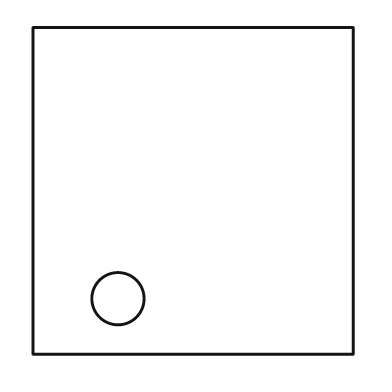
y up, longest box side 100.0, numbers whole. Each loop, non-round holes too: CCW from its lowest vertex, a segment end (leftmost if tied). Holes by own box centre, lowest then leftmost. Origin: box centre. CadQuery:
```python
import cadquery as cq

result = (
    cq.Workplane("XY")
    .moveTo(-49.0, -50.0)
    .lineTo(49.0, -50.0)
    .lineTo(49.0, 50.0)
    .lineTo(-49.0, 50.0)
    .close()
    .moveTo(-23.0, -33.0)
    .circle(8.0)
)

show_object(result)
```